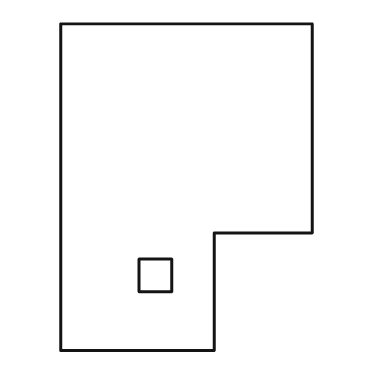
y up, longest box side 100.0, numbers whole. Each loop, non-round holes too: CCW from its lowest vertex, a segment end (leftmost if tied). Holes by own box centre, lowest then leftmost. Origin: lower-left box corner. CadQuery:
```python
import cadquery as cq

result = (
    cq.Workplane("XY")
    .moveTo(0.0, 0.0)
    .lineTo(47.0, 0.0)
    .lineTo(47.0, 36.0)
    .lineTo(77.0, 36.0)
    .lineTo(77.0, 100.0)
    .lineTo(0.0, 100.0)
    .close()
    .moveTo(24.0, 18.0)
    .lineTo(34.0, 18.0)
    .lineTo(34.0, 28.0)
    .lineTo(24.0, 28.0)
    .close()
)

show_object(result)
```